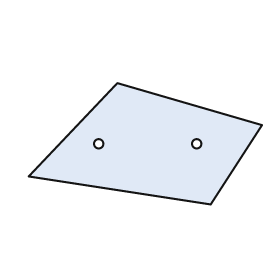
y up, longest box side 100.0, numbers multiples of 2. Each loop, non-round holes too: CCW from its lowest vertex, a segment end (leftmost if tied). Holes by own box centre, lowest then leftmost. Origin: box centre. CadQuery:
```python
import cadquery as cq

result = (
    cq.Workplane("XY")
    .moveTo(28.0, -26.0)
    .lineTo(50.0, 8.0)
    .lineTo(-12.0, 26.0)
    .lineTo(-50.0, -14.0)
    .close()
    .moveTo(-20.0, 0.0)
    .circle(2.0)
    .moveTo(22.0, 0.0)
    .circle(2.0)
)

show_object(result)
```